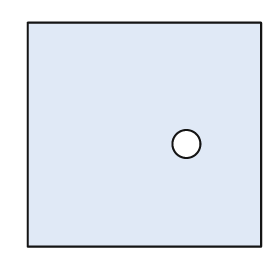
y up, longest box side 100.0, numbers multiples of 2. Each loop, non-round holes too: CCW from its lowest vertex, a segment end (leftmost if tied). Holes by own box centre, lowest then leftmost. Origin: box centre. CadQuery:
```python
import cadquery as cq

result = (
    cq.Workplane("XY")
    .moveTo(-50.0, -48.0)
    .lineTo(50.0, -48.0)
    .lineTo(50.0, 48.0)
    .lineTo(-50.0, 48.0)
    .close()
    .moveTo(18.0, -4.0)
    .circle(6.0)
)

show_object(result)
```